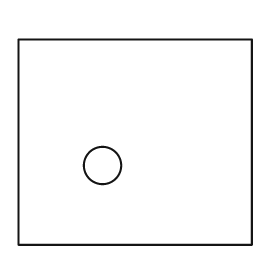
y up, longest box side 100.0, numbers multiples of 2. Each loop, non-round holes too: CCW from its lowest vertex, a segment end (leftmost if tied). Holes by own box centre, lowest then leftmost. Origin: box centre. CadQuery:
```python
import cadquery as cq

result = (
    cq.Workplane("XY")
    .moveTo(-50.0, -44.0)
    .lineTo(50.0, -44.0)
    .lineTo(50.0, 44.0)
    .lineTo(-50.0, 44.0)
    .close()
    .moveTo(-14.0, -10.0)
    .circle(8.0)
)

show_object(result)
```